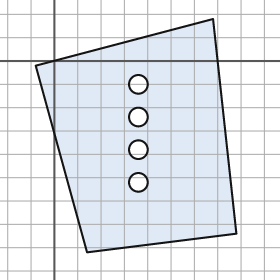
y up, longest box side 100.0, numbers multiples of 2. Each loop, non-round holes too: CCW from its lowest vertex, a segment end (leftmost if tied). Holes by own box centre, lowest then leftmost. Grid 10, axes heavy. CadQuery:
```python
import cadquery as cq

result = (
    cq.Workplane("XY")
    .moveTo(14.0, -82.0)
    .lineTo(78.0, -74.0)
    .lineTo(68.0, 18.0)
    .lineTo(-8.0, -2.0)
    .close()
    .moveTo(36.0, -52.0)
    .circle(4.0)
    .moveTo(36.0, -38.0)
    .circle(4.0)
    .moveTo(36.0, -24.0)
    .circle(4.0)
    .moveTo(36.0, -10.0)
    .circle(4.0)
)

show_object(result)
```